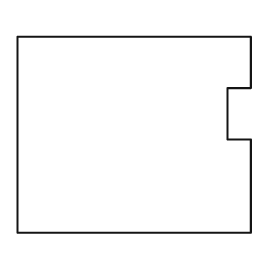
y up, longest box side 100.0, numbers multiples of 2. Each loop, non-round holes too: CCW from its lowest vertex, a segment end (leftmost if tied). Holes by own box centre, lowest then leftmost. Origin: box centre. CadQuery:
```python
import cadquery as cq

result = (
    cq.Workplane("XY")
    .moveTo(-50.0, -42.0)
    .lineTo(50.0, -42.0)
    .lineTo(50.0, -2.0)
    .lineTo(40.0, -2.0)
    .lineTo(40.0, 20.0)
    .lineTo(50.0, 20.0)
    .lineTo(50.0, 42.0)
    .lineTo(-50.0, 42.0)
    .close()
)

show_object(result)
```